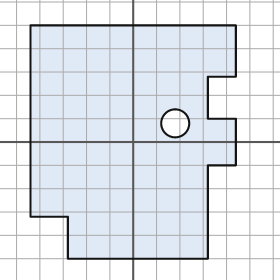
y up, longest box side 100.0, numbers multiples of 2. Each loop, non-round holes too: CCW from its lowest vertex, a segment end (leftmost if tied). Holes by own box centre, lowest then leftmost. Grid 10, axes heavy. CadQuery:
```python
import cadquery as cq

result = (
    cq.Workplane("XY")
    .moveTo(-28.0, -50.0)
    .lineTo(32.0, -50.0)
    .lineTo(32.0, -10.0)
    .lineTo(44.0, -10.0)
    .lineTo(44.0, 10.0)
    .lineTo(32.0, 10.0)
    .lineTo(32.0, 28.0)
    .lineTo(44.0, 28.0)
    .lineTo(44.0, 50.0)
    .lineTo(-44.0, 50.0)
    .lineTo(-44.0, -32.0)
    .lineTo(-28.0, -32.0)
    .close()
    .moveTo(18.0, 8.0)
    .circle(6.0)
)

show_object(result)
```